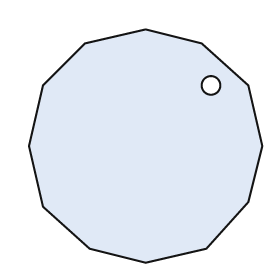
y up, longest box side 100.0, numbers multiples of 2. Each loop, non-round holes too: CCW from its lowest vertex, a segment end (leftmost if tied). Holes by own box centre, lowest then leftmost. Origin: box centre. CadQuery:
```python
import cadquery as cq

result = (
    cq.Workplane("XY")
    .moveTo(0.0, -50.0)
    .lineTo(26.0, -44.0)
    .lineTo(44.0, -24.0)
    .lineTo(50.0, 0.0)
    .lineTo(44.0, 26.0)
    .lineTo(24.0, 44.0)
    .lineTo(0.0, 50.0)
    .lineTo(-26.0, 44.0)
    .lineTo(-44.0, 26.0)
    .lineTo(-50.0, 0.0)
    .lineTo(-44.0, -26.0)
    .lineTo(-24.0, -44.0)
    .close()
    .moveTo(28.0, 26.0)
    .circle(4.0)
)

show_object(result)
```